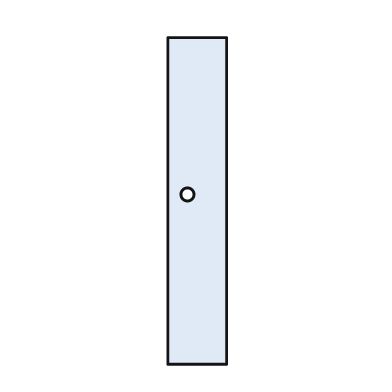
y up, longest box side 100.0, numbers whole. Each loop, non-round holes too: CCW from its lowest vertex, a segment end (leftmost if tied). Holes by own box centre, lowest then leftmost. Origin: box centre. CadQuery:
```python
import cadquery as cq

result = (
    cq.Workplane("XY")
    .moveTo(-9.0, -50.0)
    .lineTo(9.0, -50.0)
    .lineTo(9.0, 50.0)
    .lineTo(-9.0, 50.0)
    .close()
    .moveTo(-3.0, 2.0)
    .circle(2.0)
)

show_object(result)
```